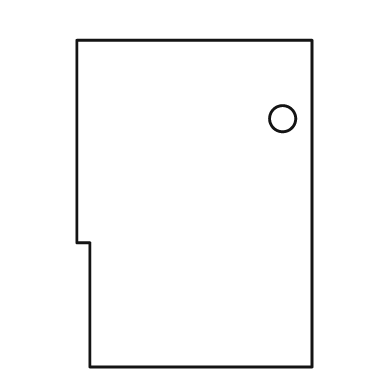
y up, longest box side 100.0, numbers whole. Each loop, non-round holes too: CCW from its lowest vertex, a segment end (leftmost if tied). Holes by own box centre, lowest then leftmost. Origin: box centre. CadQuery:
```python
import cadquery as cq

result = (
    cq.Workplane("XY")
    .moveTo(-32.0, -50.0)
    .lineTo(36.0, -50.0)
    .lineTo(36.0, 50.0)
    .lineTo(-36.0, 50.0)
    .lineTo(-36.0, -12.0)
    .lineTo(-32.0, -12.0)
    .close()
    .moveTo(27.0, 26.0)
    .circle(4.0)
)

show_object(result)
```